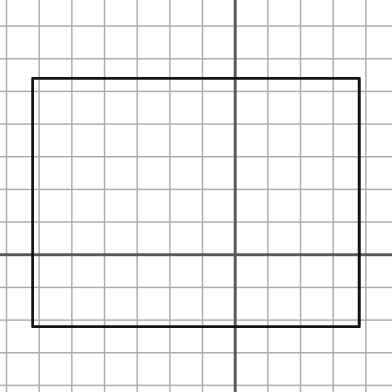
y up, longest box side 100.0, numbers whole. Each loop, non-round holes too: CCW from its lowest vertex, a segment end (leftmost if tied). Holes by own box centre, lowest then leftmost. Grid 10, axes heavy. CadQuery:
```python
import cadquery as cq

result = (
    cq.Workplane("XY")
    .moveTo(-62.0, -22.0)
    .lineTo(38.0, -22.0)
    .lineTo(38.0, 54.0)
    .lineTo(-62.0, 54.0)
    .close()
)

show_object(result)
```